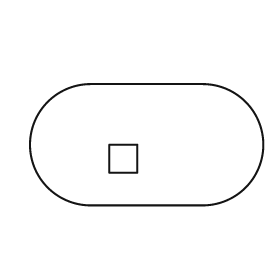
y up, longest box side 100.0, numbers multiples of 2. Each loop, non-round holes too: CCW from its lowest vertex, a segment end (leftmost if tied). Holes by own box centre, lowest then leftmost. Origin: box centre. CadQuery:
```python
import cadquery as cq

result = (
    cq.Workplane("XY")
    .moveTo(-24.0, -26.0)
    .lineTo(24.0, -26.0)
    .threePointArc((50.0, 0.0), (24.0, 26.0))
    .lineTo(-24.0, 26.0)
    .threePointArc((-50.0, 0.0), (-24.0, -26.0))
    .close()
    .moveTo(-16.0, -12.0)
    .lineTo(-4.0, -12.0)
    .lineTo(-4.0, 0.0)
    .lineTo(-16.0, 0.0)
    .close()
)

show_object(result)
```